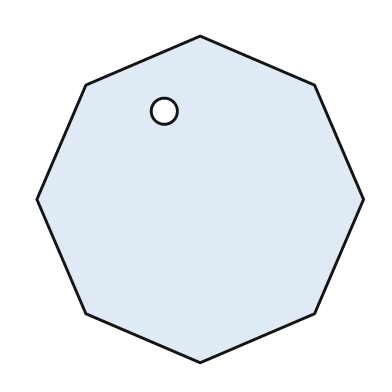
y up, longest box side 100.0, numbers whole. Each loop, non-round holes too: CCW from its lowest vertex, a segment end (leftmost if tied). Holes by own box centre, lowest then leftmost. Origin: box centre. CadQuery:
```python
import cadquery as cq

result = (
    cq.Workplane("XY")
    .moveTo(0.0, -50.0)
    .lineTo(35.0, -35.0)
    .lineTo(50.0, 0.0)
    .lineTo(35.0, 35.0)
    .lineTo(0.0, 50.0)
    .lineTo(-35.0, 35.0)
    .lineTo(-50.0, 0.0)
    .lineTo(-35.0, -35.0)
    .close()
    .moveTo(-11.0, 27.0)
    .circle(4.0)
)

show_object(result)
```